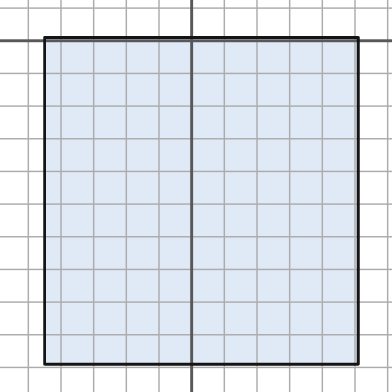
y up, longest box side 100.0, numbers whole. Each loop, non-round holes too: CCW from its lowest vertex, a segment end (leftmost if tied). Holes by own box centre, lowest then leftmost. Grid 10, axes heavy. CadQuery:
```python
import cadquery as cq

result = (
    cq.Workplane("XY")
    .moveTo(-45.0, -99.0)
    .lineTo(51.0, -99.0)
    .lineTo(51.0, 1.0)
    .lineTo(-45.0, 1.0)
    .close()
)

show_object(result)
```